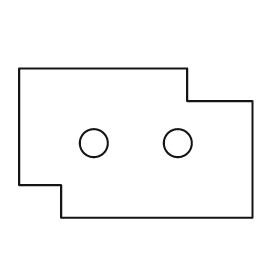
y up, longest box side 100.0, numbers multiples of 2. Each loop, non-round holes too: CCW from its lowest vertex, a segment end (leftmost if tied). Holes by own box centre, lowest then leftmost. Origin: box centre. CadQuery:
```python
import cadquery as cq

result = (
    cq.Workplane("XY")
    .moveTo(-32.0, -32.0)
    .lineTo(50.0, -32.0)
    .lineTo(50.0, 18.0)
    .lineTo(22.0, 18.0)
    .lineTo(22.0, 32.0)
    .lineTo(-50.0, 32.0)
    .lineTo(-50.0, -18.0)
    .lineTo(-32.0, -18.0)
    .close()
    .moveTo(-18.0, 0.0)
    .circle(6.0)
    .moveTo(18.0, 0.0)
    .circle(6.0)
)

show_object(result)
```